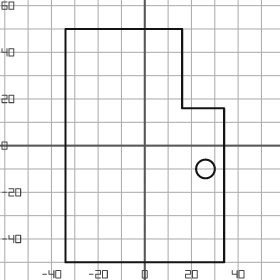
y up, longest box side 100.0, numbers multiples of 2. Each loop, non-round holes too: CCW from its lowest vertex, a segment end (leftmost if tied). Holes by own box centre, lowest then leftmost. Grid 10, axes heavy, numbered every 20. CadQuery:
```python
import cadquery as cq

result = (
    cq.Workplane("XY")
    .moveTo(-34.0, -50.0)
    .lineTo(34.0, -50.0)
    .lineTo(34.0, 16.0)
    .lineTo(16.0, 16.0)
    .lineTo(16.0, 50.0)
    .lineTo(-34.0, 50.0)
    .close()
    .moveTo(26.0, -10.0)
    .circle(4.0)
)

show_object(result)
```